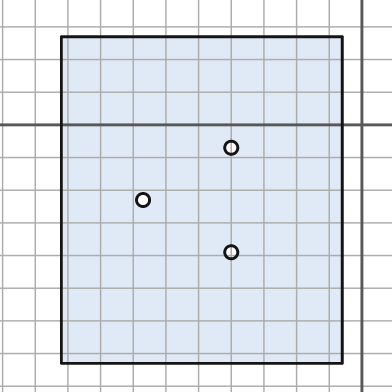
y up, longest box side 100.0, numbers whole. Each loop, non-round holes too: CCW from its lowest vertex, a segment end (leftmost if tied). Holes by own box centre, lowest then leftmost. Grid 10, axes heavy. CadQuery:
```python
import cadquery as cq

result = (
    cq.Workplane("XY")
    .moveTo(-92.0, -73.0)
    .lineTo(-6.0, -73.0)
    .lineTo(-6.0, 27.0)
    .lineTo(-92.0, 27.0)
    .close()
    .moveTo(-40.0, -39.0)
    .circle(2.0)
    .moveTo(-67.0, -23.0)
    .circle(2.0)
    .moveTo(-40.0, -7.0)
    .circle(2.0)
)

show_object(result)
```